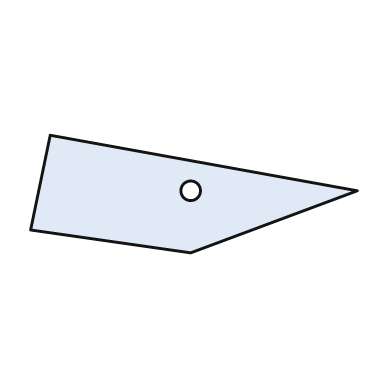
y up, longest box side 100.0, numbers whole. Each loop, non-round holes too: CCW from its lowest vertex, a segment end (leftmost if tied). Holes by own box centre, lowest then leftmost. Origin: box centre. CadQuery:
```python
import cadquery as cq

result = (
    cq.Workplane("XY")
    .moveTo(-1.0, -18.0)
    .lineTo(50.0, 1.0)
    .lineTo(-44.0, 18.0)
    .lineTo(-50.0, -11.0)
    .close()
    .moveTo(-1.0, 1.0)
    .circle(3.0)
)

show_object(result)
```